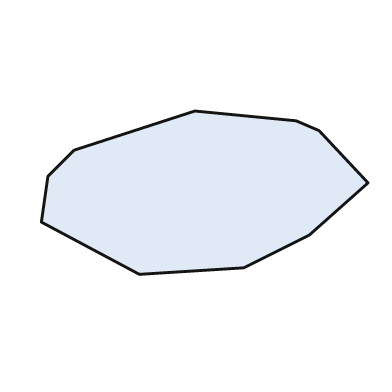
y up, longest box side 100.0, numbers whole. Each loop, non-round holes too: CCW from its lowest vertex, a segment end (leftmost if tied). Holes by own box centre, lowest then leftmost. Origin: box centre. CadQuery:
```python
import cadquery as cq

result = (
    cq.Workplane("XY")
    .moveTo(-20.0, -25.0)
    .lineTo(12.0, -23.0)
    .lineTo(32.0, -13.0)
    .lineTo(50.0, 3.0)
    .lineTo(35.0, 19.0)
    .lineTo(28.0, 22.0)
    .lineTo(-3.0, 25.0)
    .lineTo(-40.0, 13.0)
    .lineTo(-48.0, 5.0)
    .lineTo(-50.0, -9.0)
    .close()
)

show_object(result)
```